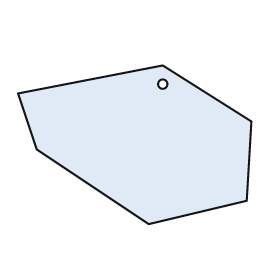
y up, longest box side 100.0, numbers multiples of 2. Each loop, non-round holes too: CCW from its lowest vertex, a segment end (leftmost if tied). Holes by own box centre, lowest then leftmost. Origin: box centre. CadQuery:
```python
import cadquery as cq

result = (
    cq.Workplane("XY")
    .moveTo(6.0, -34.0)
    .lineTo(48.0, -24.0)
    .lineTo(50.0, 10.0)
    .lineTo(12.0, 34.0)
    .lineTo(-50.0, 22.0)
    .lineTo(-42.0, -2.0)
    .close()
    .moveTo(12.0, 26.0)
    .circle(2.0)
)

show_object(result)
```